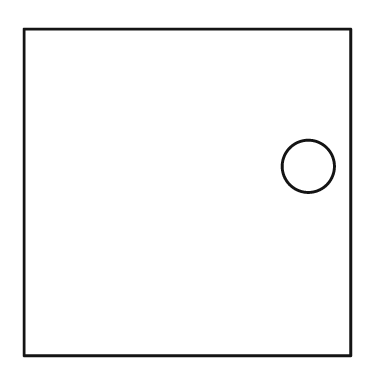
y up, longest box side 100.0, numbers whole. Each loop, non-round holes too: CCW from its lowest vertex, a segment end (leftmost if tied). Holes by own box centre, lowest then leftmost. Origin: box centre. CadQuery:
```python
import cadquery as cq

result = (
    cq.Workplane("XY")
    .moveTo(-50.0, -50.0)
    .lineTo(50.0, -50.0)
    .lineTo(50.0, 50.0)
    .lineTo(-50.0, 50.0)
    .close()
    .moveTo(37.0, 8.0)
    .circle(8.0)
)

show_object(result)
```